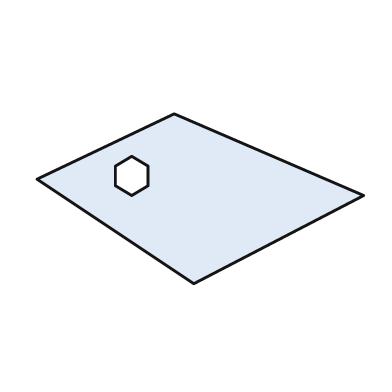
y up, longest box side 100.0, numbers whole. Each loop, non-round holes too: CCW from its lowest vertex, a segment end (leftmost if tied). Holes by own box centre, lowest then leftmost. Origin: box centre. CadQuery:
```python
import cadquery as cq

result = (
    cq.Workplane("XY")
    .moveTo(-2.0, -26.0)
    .lineTo(50.0, 1.0)
    .lineTo(-8.0, 26.0)
    .lineTo(-50.0, 6.0)
    .close()
    .moveTo(-21.0, 1.0)
    .lineTo(-16.0, 4.0)
    .lineTo(-16.0, 10.0)
    .lineTo(-21.0, 13.0)
    .lineTo(-26.0, 10.0)
    .lineTo(-26.0, 4.0)
    .close()
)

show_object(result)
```